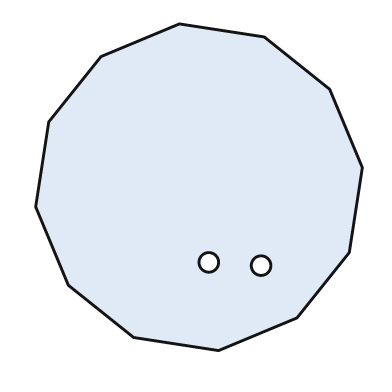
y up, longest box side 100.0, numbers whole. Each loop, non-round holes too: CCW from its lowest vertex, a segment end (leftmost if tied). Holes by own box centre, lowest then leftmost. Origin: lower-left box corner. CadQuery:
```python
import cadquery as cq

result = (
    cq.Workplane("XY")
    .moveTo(56.0, 0.0)
    .lineTo(80.0, 10.0)
    .lineTo(96.0, 30.0)
    .lineTo(100.0, 56.0)
    .lineTo(90.0, 80.0)
    .lineTo(70.0, 96.0)
    .lineTo(44.0, 100.0)
    .lineTo(20.0, 90.0)
    .lineTo(4.0, 70.0)
    .lineTo(0.0, 44.0)
    .lineTo(10.0, 20.0)
    .lineTo(30.0, 4.0)
    .close()
    .moveTo(69.0, 26.0)
    .circle(3.0)
    .moveTo(53.0, 27.0)
    .circle(3.0)
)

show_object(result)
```